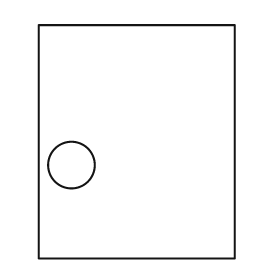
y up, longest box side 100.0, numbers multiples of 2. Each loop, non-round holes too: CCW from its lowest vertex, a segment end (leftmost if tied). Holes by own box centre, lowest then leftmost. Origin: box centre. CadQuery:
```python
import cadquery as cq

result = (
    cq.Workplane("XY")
    .moveTo(-42.0, -50.0)
    .lineTo(42.0, -50.0)
    .lineTo(42.0, 50.0)
    .lineTo(-42.0, 50.0)
    .close()
    .moveTo(-28.0, -10.0)
    .circle(10.0)
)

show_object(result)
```